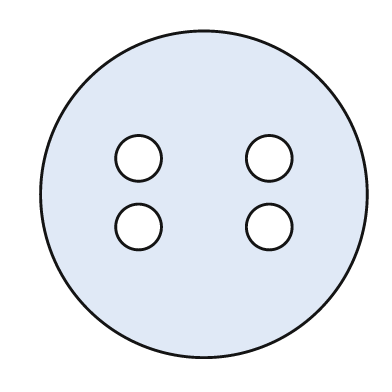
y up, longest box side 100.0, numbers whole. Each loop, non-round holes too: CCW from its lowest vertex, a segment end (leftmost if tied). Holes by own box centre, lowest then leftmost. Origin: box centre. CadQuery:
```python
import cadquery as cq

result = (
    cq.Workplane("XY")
    .moveTo(0.0, 0.0)
    .circle(50.0)
    .moveTo(-20.0, -10.0)
    .circle(7.0)
    .moveTo(20.0, -10.0)
    .circle(7.0)
    .moveTo(-20.0, 11.0)
    .circle(7.0)
    .moveTo(20.0, 11.0)
    .circle(7.0)
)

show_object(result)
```